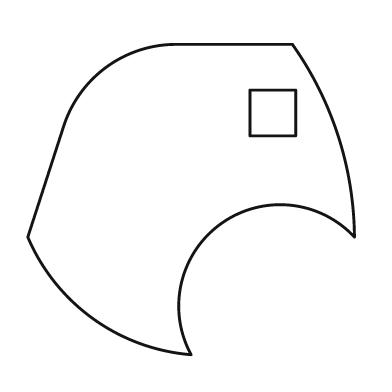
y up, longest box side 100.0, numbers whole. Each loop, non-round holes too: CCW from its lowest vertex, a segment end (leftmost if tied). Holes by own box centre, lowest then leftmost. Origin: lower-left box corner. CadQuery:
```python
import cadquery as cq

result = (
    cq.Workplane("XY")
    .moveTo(50.0, 0.0)
    .threePointArc((59.0, 40.0), (100.0, 36.0))
    .threePointArc((95.0, 67.0), (81.0, 95.0))
    .lineTo(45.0, 95.0)
    .threePointArc((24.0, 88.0), (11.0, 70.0))
    .lineTo(0.0, 36.0)
    .threePointArc((20.0, 11.0), (50.0, 0.0))
    .close()
    .moveTo(68.0, 67.0)
    .lineTo(82.0, 67.0)
    .lineTo(82.0, 81.0)
    .lineTo(68.0, 81.0)
    .close()
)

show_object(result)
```